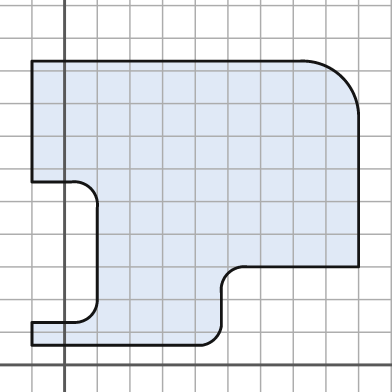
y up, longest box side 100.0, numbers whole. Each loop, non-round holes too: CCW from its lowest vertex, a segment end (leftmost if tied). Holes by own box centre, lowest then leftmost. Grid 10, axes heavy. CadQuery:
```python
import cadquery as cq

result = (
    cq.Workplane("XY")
    .moveTo(-10.0, 6.0)
    .lineTo(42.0, 6.0)
    .threePointArc((46.0, 8.0), (48.0, 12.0))
    .lineTo(48.0, 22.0)
    .threePointArc((50.0, 28.0), (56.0, 30.0))
    .lineTo(90.0, 30.0)
    .lineTo(90.0, 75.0)
    .threePointArc((85.0, 88.0), (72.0, 93.0))
    .lineTo(-10.0, 93.0)
    .lineTo(-10.0, 56.0)
    .lineTo(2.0, 56.0)
    .threePointArc((8.0, 54.0), (10.0, 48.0))
    .lineTo(10.0, 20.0)
    .threePointArc((8.0, 15.0), (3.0, 13.0))
    .lineTo(-10.0, 13.0)
    .close()
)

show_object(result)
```